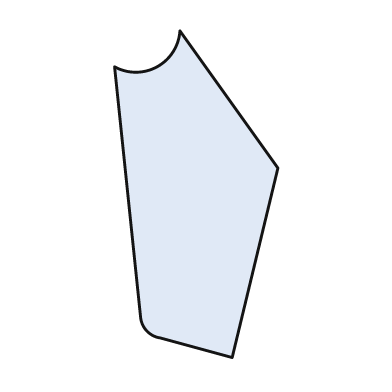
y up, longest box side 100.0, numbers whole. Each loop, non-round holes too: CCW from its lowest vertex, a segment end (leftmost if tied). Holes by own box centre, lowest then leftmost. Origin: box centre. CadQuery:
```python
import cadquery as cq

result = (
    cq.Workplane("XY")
    .moveTo(11.0, -50.0)
    .lineTo(25.0, 8.0)
    .lineTo(-5.0, 50.0)
    .threePointArc((-12.0, 39.0), (-25.0, 39.0))
    .lineTo(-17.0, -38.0)
    .threePointArc((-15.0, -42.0), (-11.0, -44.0))
    .close()
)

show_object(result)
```